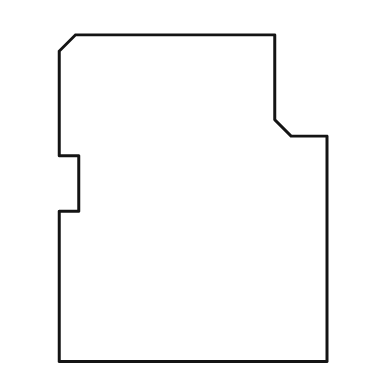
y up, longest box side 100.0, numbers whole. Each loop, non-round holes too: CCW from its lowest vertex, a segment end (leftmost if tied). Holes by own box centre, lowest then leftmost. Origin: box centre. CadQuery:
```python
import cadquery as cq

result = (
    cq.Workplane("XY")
    .moveTo(-41.0, -50.0)
    .lineTo(41.0, -50.0)
    .lineTo(41.0, 19.0)
    .lineTo(30.0, 19.0)
    .lineTo(25.0, 24.0)
    .lineTo(25.0, 50.0)
    .lineTo(-36.0, 50.0)
    .lineTo(-41.0, 45.0)
    .lineTo(-41.0, 13.0)
    .lineTo(-35.0, 13.0)
    .lineTo(-35.0, -4.0)
    .lineTo(-41.0, -4.0)
    .close()
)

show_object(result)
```